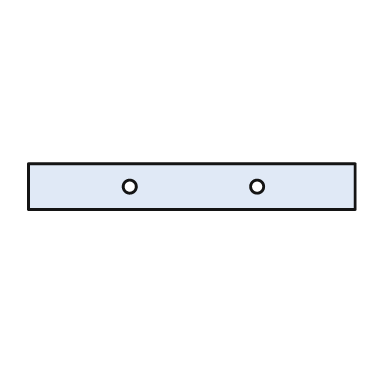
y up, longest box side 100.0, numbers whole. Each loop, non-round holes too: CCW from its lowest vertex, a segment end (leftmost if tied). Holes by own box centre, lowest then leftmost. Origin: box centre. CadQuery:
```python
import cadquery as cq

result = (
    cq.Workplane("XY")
    .moveTo(-50.0, -7.0)
    .lineTo(50.0, -7.0)
    .lineTo(50.0, 7.0)
    .lineTo(-50.0, 7.0)
    .close()
    .moveTo(-19.0, 0.0)
    .circle(2.0)
    .moveTo(20.0, 0.0)
    .circle(2.0)
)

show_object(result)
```